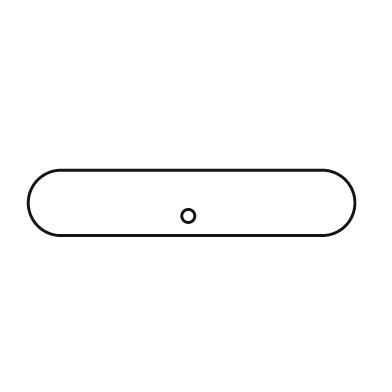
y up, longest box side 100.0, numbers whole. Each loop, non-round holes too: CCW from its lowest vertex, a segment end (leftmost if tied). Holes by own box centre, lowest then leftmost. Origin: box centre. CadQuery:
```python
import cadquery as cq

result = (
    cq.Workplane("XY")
    .moveTo(-40.0, -10.0)
    .lineTo(40.0, -10.0)
    .threePointArc((50.0, 0.0), (40.0, 10.0))
    .lineTo(-40.0, 10.0)
    .threePointArc((-50.0, 0.0), (-40.0, -10.0))
    .close()
    .moveTo(-1.0, -4.0)
    .circle(2.0)
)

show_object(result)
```